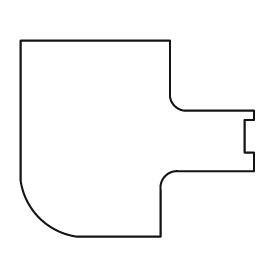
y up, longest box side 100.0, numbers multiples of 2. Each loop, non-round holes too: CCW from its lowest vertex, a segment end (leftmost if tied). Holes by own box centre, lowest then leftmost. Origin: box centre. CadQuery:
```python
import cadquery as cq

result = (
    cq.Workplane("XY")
    .moveTo(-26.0, -42.0)
    .lineTo(10.0, -42.0)
    .lineTo(10.0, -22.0)
    .threePointArc((12.0, -16.0), (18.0, -14.0))
    .lineTo(50.0, -14.0)
    .lineTo(50.0, -6.0)
    .lineTo(46.0, -6.0)
    .lineTo(46.0, 8.0)
    .lineTo(50.0, 8.0)
    .lineTo(50.0, 12.0)
    .lineTo(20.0, 12.0)
    .threePointArc((16.0, 14.0), (14.0, 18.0))
    .lineTo(14.0, 42.0)
    .lineTo(-50.0, 42.0)
    .lineTo(-50.0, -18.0)
    .threePointArc((-42.0, -34.0), (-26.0, -42.0))
    .close()
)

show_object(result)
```